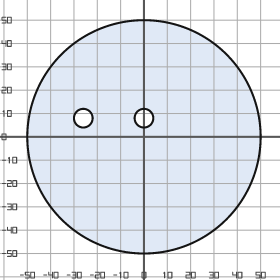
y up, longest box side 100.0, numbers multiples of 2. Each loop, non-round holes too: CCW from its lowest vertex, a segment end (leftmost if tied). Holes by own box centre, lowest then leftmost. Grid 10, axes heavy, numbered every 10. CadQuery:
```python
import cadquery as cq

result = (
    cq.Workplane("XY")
    .moveTo(0.0, 0.0)
    .circle(50.0)
    .moveTo(-26.0, 8.0)
    .circle(4.0)
    .moveTo(0.0, 8.0)
    .circle(4.0)
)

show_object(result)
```